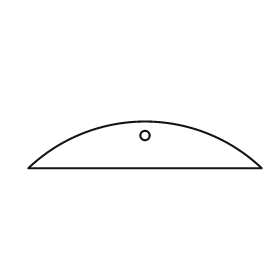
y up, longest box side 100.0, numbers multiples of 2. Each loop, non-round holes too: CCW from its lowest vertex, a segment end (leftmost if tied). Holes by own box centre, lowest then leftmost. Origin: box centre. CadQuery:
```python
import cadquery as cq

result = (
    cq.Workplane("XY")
    .moveTo(-50.0, -10.0)
    .lineTo(50.0, -10.0)
    .threePointArc((0.0, 10.0), (-50.0, -10.0))
    .close()
    .moveTo(0.0, 4.0)
    .circle(2.0)
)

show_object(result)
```